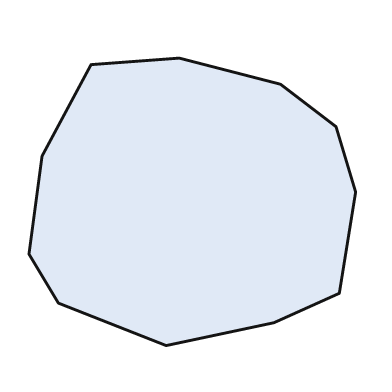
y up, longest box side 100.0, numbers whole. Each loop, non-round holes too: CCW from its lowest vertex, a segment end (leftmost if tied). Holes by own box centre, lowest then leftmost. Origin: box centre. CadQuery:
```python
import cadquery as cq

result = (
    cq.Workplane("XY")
    .moveTo(-8.0, -44.0)
    .lineTo(25.0, -37.0)
    .lineTo(45.0, -28.0)
    .lineTo(50.0, 3.0)
    .lineTo(44.0, 23.0)
    .lineTo(27.0, 36.0)
    .lineTo(-4.0, 44.0)
    .lineTo(-31.0, 42.0)
    .lineTo(-46.0, 14.0)
    .lineTo(-50.0, -16.0)
    .lineTo(-41.0, -31.0)
    .close()
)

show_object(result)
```